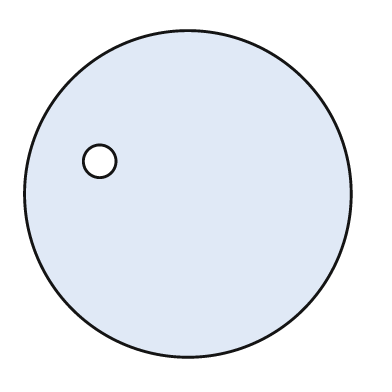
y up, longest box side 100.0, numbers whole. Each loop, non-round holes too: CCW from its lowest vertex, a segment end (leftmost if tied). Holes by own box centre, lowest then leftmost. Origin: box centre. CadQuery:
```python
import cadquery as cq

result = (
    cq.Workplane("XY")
    .moveTo(0.0, 0.0)
    .circle(50.0)
    .moveTo(-27.0, 10.0)
    .circle(5.0)
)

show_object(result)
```